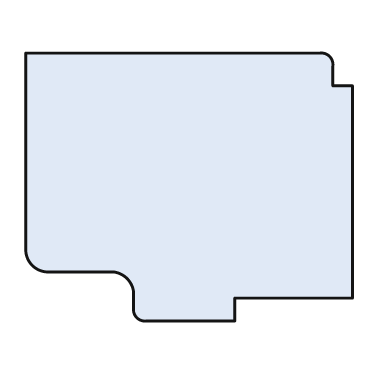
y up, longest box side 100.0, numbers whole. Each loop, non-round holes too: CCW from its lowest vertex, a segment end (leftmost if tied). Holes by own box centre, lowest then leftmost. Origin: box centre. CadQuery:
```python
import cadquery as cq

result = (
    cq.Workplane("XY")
    .moveTo(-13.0, -41.0)
    .lineTo(14.0, -41.0)
    .lineTo(14.0, -34.0)
    .lineTo(50.0, -34.0)
    .lineTo(50.0, 31.0)
    .lineTo(44.0, 31.0)
    .lineTo(44.0, 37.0)
    .threePointArc((43.0, 40.0), (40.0, 41.0))
    .lineTo(-50.0, 41.0)
    .lineTo(-50.0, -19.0)
    .threePointArc((-48.0, -24.0), (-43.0, -26.0))
    .lineTo(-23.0, -26.0)
    .threePointArc((-19.0, -28.0), (-17.0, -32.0))
    .lineTo(-17.0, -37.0)
    .threePointArc((-16.0, -40.0), (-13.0, -41.0))
    .close()
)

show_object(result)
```